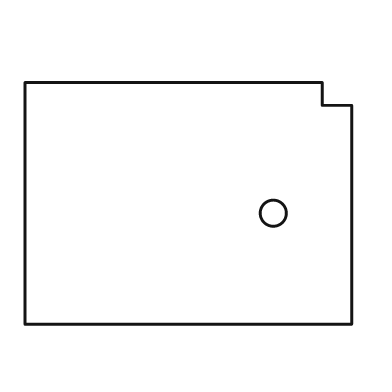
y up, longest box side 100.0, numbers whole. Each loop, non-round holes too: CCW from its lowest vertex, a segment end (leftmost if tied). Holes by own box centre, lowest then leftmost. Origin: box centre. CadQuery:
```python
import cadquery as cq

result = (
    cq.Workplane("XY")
    .moveTo(-50.0, -37.0)
    .lineTo(50.0, -37.0)
    .lineTo(50.0, 30.0)
    .lineTo(41.0, 30.0)
    .lineTo(41.0, 37.0)
    .lineTo(-50.0, 37.0)
    .close()
    .moveTo(26.0, -3.0)
    .circle(4.0)
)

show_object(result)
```